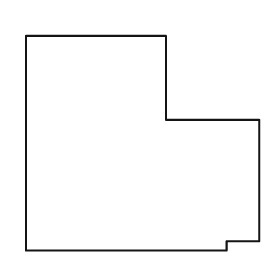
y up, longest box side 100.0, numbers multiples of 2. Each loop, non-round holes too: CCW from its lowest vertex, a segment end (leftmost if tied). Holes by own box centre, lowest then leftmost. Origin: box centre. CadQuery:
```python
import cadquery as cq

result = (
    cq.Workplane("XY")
    .moveTo(-50.0, -46.0)
    .lineTo(36.0, -46.0)
    .lineTo(36.0, -42.0)
    .lineTo(50.0, -42.0)
    .lineTo(50.0, 10.0)
    .lineTo(10.0, 10.0)
    .lineTo(10.0, 46.0)
    .lineTo(-50.0, 46.0)
    .close()
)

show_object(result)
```